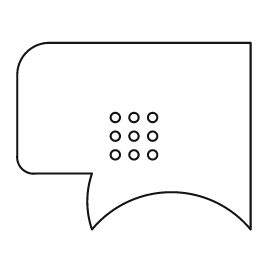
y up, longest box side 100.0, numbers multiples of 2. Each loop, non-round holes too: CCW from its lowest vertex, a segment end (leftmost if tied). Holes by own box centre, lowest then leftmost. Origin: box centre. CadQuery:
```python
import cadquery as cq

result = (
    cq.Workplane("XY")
    .moveTo(-18.0, -40.0)
    .threePointArc((16.0, -24.0), (50.0, -40.0))
    .lineTo(50.0, 40.0)
    .lineTo(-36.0, 40.0)
    .threePointArc((-46.0, 36.0), (-50.0, 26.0))
    .lineTo(-50.0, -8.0)
    .threePointArc((-48.0, -14.0), (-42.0, -16.0))
    .lineTo(-18.0, -16.0)
    .threePointArc((-20.0, -28.0), (-18.0, -40.0))
    .close()
    .moveTo(-8.0, -8.0)
    .circle(2.0)
    .moveTo(0.0, -8.0)
    .circle(2.0)
    .moveTo(8.0, -8.0)
    .circle(2.0)
    .moveTo(-8.0, 0.0)
    .circle(2.0)
    .moveTo(0.0, 0.0)
    .circle(2.0)
    .moveTo(8.0, 0.0)
    .circle(2.0)
    .moveTo(-8.0, 8.0)
    .circle(2.0)
    .moveTo(0.0, 8.0)
    .circle(2.0)
    .moveTo(8.0, 8.0)
    .circle(2.0)
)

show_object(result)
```